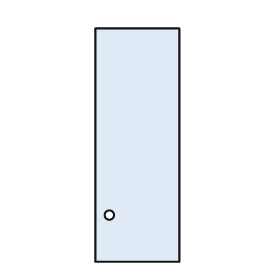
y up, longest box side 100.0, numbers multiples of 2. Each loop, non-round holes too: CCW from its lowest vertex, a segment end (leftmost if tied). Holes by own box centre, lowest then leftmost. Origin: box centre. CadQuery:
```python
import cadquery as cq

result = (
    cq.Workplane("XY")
    .moveTo(-18.0, -50.0)
    .lineTo(18.0, -50.0)
    .lineTo(18.0, 50.0)
    .lineTo(-18.0, 50.0)
    .close()
    .moveTo(-12.0, -30.0)
    .circle(2.0)
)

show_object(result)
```